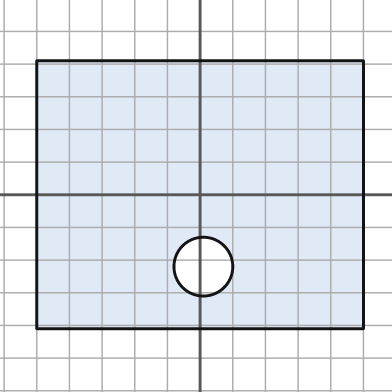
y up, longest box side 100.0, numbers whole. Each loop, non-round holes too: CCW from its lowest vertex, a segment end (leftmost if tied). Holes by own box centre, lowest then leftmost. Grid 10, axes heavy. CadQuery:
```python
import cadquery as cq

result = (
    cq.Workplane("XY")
    .moveTo(-50.0, -41.0)
    .lineTo(50.0, -41.0)
    .lineTo(50.0, 41.0)
    .lineTo(-50.0, 41.0)
    .close()
    .moveTo(1.0, -22.0)
    .circle(9.0)
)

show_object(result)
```